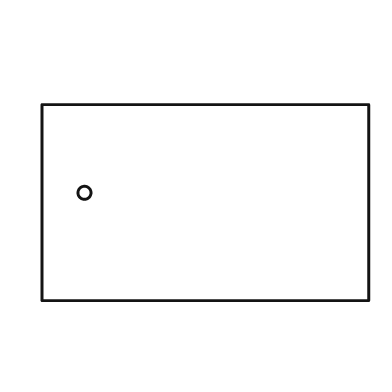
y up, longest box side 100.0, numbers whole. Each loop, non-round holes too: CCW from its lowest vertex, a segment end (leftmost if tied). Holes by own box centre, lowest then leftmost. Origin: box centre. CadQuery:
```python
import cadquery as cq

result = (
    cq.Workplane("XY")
    .moveTo(-50.0, -30.0)
    .lineTo(50.0, -30.0)
    .lineTo(50.0, 30.0)
    .lineTo(-50.0, 30.0)
    .close()
    .moveTo(-37.0, 3.0)
    .circle(2.0)
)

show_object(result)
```